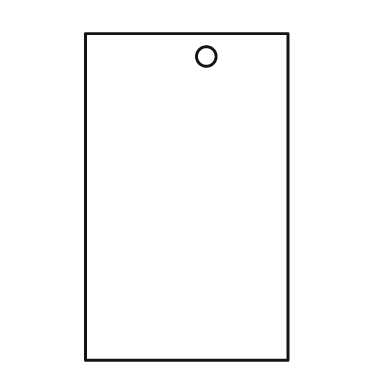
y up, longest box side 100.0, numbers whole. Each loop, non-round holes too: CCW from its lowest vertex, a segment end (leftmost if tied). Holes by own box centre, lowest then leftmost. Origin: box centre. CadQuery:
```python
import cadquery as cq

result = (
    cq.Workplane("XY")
    .moveTo(-31.0, -50.0)
    .lineTo(31.0, -50.0)
    .lineTo(31.0, 50.0)
    .lineTo(-31.0, 50.0)
    .close()
    .moveTo(6.0, 43.0)
    .circle(3.0)
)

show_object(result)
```